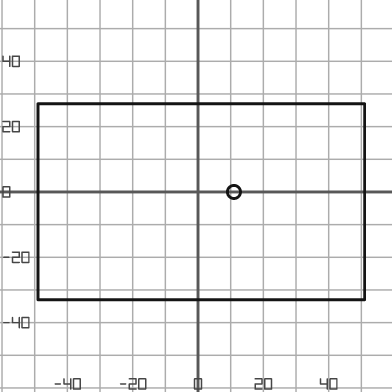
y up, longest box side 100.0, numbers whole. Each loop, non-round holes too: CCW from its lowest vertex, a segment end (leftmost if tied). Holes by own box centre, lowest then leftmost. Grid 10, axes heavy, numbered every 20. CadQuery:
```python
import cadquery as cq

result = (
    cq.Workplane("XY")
    .moveTo(-49.0, -33.0)
    .lineTo(51.0, -33.0)
    .lineTo(51.0, 27.0)
    .lineTo(-49.0, 27.0)
    .close()
    .moveTo(11.0, 0.0)
    .circle(2.0)
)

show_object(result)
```